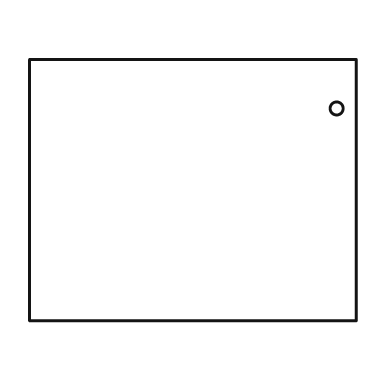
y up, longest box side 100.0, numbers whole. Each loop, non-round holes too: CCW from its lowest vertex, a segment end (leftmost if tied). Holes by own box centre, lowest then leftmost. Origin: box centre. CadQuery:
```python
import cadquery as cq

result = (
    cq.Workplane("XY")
    .moveTo(-50.0, -40.0)
    .lineTo(50.0, -40.0)
    .lineTo(50.0, 40.0)
    .lineTo(-50.0, 40.0)
    .close()
    .moveTo(44.0, 25.0)
    .circle(2.0)
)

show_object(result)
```